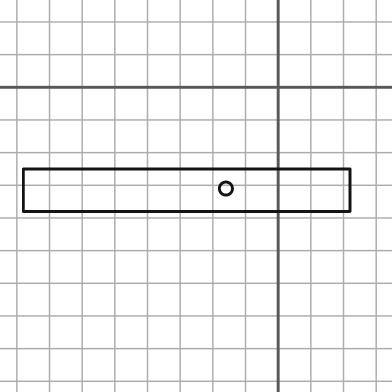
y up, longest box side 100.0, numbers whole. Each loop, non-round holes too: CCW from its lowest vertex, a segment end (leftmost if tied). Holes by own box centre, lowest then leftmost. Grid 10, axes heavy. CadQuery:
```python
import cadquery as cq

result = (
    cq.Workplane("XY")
    .moveTo(-78.0, -38.0)
    .lineTo(22.0, -38.0)
    .lineTo(22.0, -25.0)
    .lineTo(-78.0, -25.0)
    .close()
    .moveTo(-16.0, -31.0)
    .circle(2.0)
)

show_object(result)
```